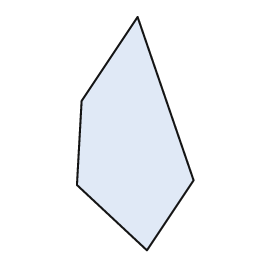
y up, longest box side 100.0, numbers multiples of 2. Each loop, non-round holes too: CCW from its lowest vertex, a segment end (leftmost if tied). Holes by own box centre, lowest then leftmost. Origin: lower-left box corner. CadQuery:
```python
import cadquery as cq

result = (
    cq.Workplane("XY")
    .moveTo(30.0, 0.0)
    .lineTo(50.0, 30.0)
    .lineTo(26.0, 100.0)
    .lineTo(2.0, 64.0)
    .lineTo(0.0, 28.0)
    .close()
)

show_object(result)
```